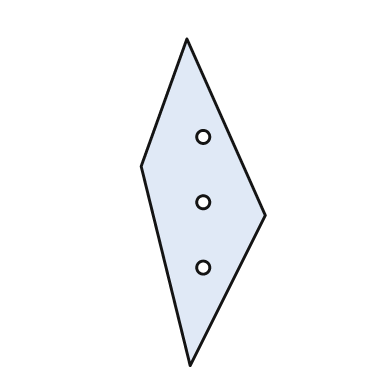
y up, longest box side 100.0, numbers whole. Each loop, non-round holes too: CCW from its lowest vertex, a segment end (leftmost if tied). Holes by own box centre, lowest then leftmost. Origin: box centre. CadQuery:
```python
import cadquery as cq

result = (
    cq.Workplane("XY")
    .moveTo(-4.0, -50.0)
    .lineTo(19.0, -4.0)
    .lineTo(-5.0, 50.0)
    .lineTo(-19.0, 11.0)
    .close()
    .moveTo(0.0, -20.0)
    .circle(2.0)
    .moveTo(0.0, 0.0)
    .circle(2.0)
    .moveTo(0.0, 20.0)
    .circle(2.0)
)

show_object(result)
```